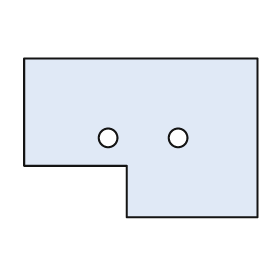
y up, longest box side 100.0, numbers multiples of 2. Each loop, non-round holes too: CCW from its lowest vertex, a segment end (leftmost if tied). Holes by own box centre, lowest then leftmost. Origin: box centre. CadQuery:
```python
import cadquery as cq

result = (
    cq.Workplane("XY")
    .moveTo(-6.0, -34.0)
    .lineTo(50.0, -34.0)
    .lineTo(50.0, 34.0)
    .lineTo(-50.0, 34.0)
    .lineTo(-50.0, -12.0)
    .lineTo(-6.0, -12.0)
    .close()
    .moveTo(-14.0, 0.0)
    .circle(4.0)
    .moveTo(16.0, 0.0)
    .circle(4.0)
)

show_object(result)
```